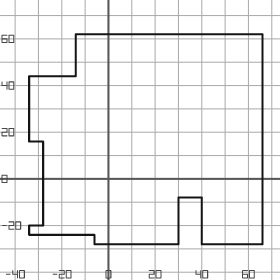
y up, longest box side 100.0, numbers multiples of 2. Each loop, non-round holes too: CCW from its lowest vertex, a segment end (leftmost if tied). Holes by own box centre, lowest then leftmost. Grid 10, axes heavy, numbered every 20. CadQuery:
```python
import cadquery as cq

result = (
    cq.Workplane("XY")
    .moveTo(-6.0, -28.0)
    .lineTo(30.0, -28.0)
    .lineTo(30.0, -8.0)
    .lineTo(40.0, -8.0)
    .lineTo(40.0, -28.0)
    .lineTo(66.0, -28.0)
    .lineTo(66.0, 62.0)
    .lineTo(-14.0, 62.0)
    .lineTo(-14.0, 44.0)
    .lineTo(-34.0, 44.0)
    .lineTo(-34.0, 16.0)
    .lineTo(-28.0, 16.0)
    .lineTo(-28.0, -20.0)
    .lineTo(-34.0, -20.0)
    .lineTo(-34.0, -24.0)
    .lineTo(-6.0, -24.0)
    .close()
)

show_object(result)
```